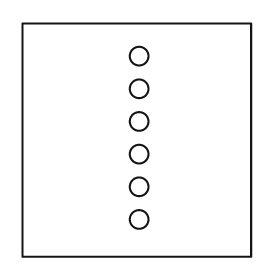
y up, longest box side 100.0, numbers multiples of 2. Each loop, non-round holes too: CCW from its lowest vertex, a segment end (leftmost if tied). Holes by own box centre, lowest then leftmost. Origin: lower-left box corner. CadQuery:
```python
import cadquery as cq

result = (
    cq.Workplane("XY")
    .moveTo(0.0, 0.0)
    .lineTo(98.0, 0.0)
    .lineTo(98.0, 100.0)
    .lineTo(0.0, 100.0)
    .close()
    .moveTo(50.0, 16.0)
    .circle(4.0)
    .moveTo(50.0, 30.0)
    .circle(4.0)
    .moveTo(50.0, 44.0)
    .circle(4.0)
    .moveTo(50.0, 58.0)
    .circle(4.0)
    .moveTo(50.0, 72.0)
    .circle(4.0)
    .moveTo(50.0, 86.0)
    .circle(4.0)
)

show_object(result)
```